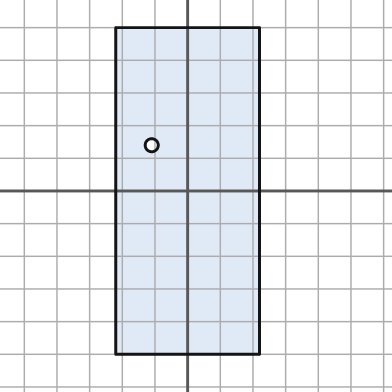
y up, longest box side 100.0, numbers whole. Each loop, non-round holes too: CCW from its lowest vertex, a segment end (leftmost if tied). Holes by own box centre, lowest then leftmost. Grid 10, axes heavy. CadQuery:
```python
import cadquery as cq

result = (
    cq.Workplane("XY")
    .moveTo(-22.0, -50.0)
    .lineTo(22.0, -50.0)
    .lineTo(22.0, 50.0)
    .lineTo(-22.0, 50.0)
    .close()
    .moveTo(-11.0, 14.0)
    .circle(2.0)
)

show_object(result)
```